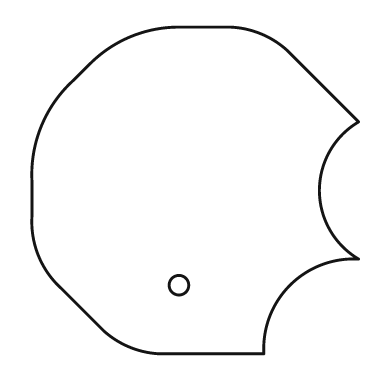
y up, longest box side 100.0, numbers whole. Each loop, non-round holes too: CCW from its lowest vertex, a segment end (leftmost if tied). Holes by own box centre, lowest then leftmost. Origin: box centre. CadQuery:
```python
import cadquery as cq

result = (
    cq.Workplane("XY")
    .moveTo(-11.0, -50.0)
    .lineTo(21.0, -50.0)
    .threePointArc((29.0, -29.0), (50.0, -21.0))
    .threePointArc((38.0, 0.0), (50.0, 21.0))
    .lineTo(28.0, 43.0)
    .threePointArc((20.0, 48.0), (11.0, 50.0))
    .lineTo(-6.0, 50.0)
    .threePointArc((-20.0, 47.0), (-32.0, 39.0))
    .lineTo(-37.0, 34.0)
    .threePointArc((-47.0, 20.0), (-50.0, 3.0))
    .lineTo(-50.0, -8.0)
    .threePointArc((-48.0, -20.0), (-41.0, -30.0))
    .lineTo(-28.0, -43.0)
    .threePointArc((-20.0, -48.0), (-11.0, -50.0))
    .close()
    .moveTo(-5.0, -29.0)
    .circle(3.0)
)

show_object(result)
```